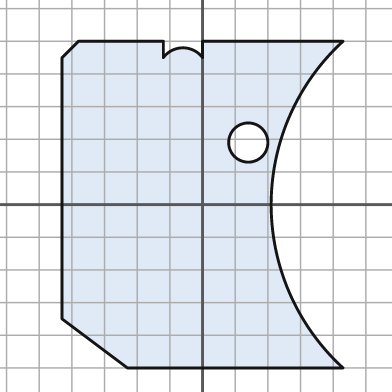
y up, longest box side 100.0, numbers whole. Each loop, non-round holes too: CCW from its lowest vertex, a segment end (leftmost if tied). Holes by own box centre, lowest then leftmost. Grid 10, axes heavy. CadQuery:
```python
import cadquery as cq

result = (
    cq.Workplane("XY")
    .moveTo(-23.0, -50.0)
    .lineTo(43.0, -50.0)
    .threePointArc((21.0, 0.0), (43.0, 50.0))
    .lineTo(0.0, 50.0)
    .lineTo(0.0, 45.0)
    .threePointArc((-6.0, 48.0), (-12.0, 45.0))
    .lineTo(-12.0, 50.0)
    .lineTo(-38.0, 50.0)
    .lineTo(-43.0, 45.0)
    .lineTo(-43.0, -35.0)
    .close()
    .moveTo(14.0, 19.0)
    .circle(6.0)
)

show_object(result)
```